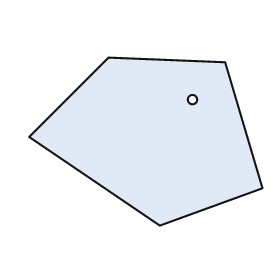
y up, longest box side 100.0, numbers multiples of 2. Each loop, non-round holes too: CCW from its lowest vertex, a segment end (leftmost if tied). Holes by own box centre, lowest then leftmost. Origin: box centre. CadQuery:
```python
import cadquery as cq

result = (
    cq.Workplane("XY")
    .moveTo(6.0, -36.0)
    .lineTo(50.0, -20.0)
    .lineTo(34.0, 34.0)
    .lineTo(-16.0, 36.0)
    .lineTo(-50.0, 2.0)
    .close()
    .moveTo(20.0, 18.0)
    .circle(2.0)
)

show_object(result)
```